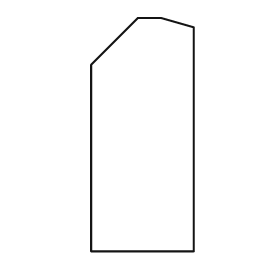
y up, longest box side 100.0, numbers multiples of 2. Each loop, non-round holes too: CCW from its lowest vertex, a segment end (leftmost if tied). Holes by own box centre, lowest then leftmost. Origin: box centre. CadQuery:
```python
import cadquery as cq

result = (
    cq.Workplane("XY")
    .moveTo(-22.0, -50.0)
    .lineTo(22.0, -50.0)
    .lineTo(22.0, 46.0)
    .lineTo(8.0, 50.0)
    .lineTo(-2.0, 50.0)
    .lineTo(-22.0, 30.0)
    .close()
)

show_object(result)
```